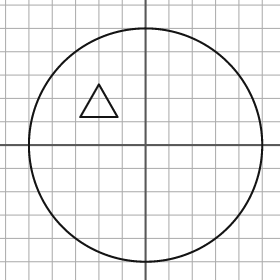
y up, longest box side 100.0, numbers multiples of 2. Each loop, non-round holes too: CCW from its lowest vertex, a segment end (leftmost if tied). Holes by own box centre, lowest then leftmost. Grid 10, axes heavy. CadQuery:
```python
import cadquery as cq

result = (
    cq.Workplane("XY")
    .moveTo(0.0, 0.0)
    .circle(50.0)
    .moveTo(-28.0, 12.0)
    .lineTo(-12.0, 12.0)
    .lineTo(-20.0, 26.0)
    .close()
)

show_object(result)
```